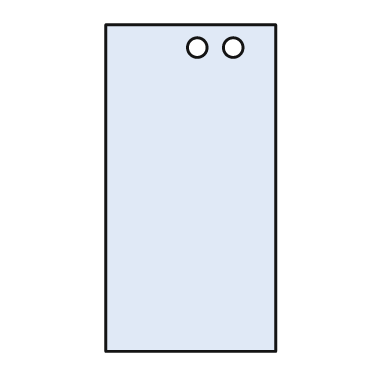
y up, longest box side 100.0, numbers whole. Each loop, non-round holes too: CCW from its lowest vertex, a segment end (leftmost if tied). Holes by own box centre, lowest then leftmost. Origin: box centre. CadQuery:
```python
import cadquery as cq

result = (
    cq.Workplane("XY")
    .moveTo(-26.0, -50.0)
    .lineTo(26.0, -50.0)
    .lineTo(26.0, 50.0)
    .lineTo(-26.0, 50.0)
    .close()
    .moveTo(2.0, 43.0)
    .circle(3.0)
    .moveTo(13.0, 43.0)
    .circle(3.0)
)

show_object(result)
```